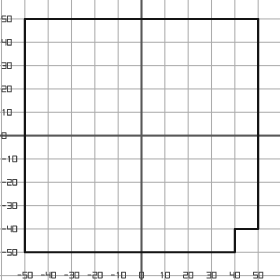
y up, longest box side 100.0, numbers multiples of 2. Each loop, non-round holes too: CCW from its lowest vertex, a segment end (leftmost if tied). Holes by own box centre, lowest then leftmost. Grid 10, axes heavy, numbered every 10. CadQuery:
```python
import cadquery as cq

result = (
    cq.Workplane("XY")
    .moveTo(-50.0, -50.0)
    .lineTo(40.0, -50.0)
    .lineTo(40.0, -40.0)
    .lineTo(50.0, -40.0)
    .lineTo(50.0, 50.0)
    .lineTo(-50.0, 50.0)
    .close()
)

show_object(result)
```